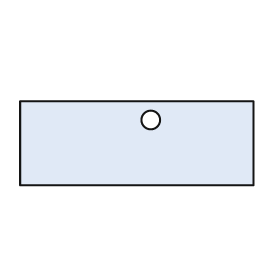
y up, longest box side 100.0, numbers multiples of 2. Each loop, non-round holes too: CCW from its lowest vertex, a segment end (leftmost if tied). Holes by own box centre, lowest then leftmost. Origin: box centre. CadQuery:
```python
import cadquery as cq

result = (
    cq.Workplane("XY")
    .moveTo(-50.0, -18.0)
    .lineTo(50.0, -18.0)
    .lineTo(50.0, 18.0)
    .lineTo(-50.0, 18.0)
    .close()
    .moveTo(6.0, 10.0)
    .circle(4.0)
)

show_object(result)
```